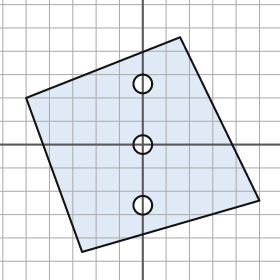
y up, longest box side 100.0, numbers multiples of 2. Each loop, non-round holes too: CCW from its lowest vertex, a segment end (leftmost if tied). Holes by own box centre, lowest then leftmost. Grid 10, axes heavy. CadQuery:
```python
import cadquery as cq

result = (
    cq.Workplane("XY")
    .moveTo(-26.0, -46.0)
    .lineTo(50.0, -24.0)
    .lineTo(16.0, 46.0)
    .lineTo(-50.0, 20.0)
    .close()
    .moveTo(0.0, -26.0)
    .circle(4.0)
    .moveTo(0.0, 0.0)
    .circle(4.0)
    .moveTo(0.0, 26.0)
    .circle(4.0)
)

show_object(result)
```